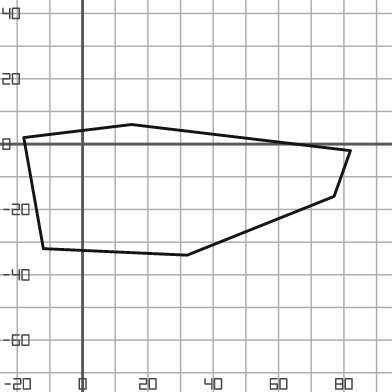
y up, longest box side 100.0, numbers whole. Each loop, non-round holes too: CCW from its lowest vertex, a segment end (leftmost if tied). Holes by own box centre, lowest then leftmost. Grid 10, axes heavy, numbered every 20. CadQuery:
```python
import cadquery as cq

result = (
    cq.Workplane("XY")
    .moveTo(32.0, -34.0)
    .lineTo(77.0, -16.0)
    .lineTo(82.0, -2.0)
    .lineTo(15.0, 6.0)
    .lineTo(-18.0, 2.0)
    .lineTo(-12.0, -32.0)
    .close()
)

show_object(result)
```